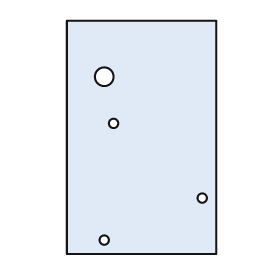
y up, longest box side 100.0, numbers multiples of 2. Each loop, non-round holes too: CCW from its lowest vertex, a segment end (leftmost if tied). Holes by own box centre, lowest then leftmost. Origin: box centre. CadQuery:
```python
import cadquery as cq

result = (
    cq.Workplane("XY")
    .moveTo(-32.0, -50.0)
    .lineTo(32.0, -50.0)
    .lineTo(32.0, 50.0)
    .lineTo(-32.0, 50.0)
    .close()
    .moveTo(-16.0, -44.0)
    .circle(2.0)
    .moveTo(26.0, -26.0)
    .circle(2.0)
    .moveTo(-12.0, 6.0)
    .circle(2.0)
    .moveTo(-16.0, 26.0)
    .circle(4.0)
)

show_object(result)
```